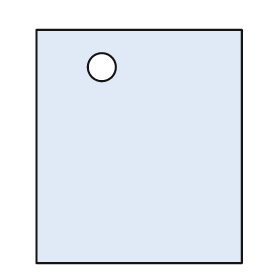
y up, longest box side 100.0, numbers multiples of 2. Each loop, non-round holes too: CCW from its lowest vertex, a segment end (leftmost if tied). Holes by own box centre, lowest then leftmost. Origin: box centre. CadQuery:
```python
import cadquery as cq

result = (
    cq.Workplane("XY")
    .moveTo(-44.0, -50.0)
    .lineTo(44.0, -50.0)
    .lineTo(44.0, 50.0)
    .lineTo(-44.0, 50.0)
    .close()
    .moveTo(-16.0, 34.0)
    .circle(6.0)
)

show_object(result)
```